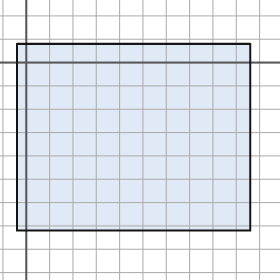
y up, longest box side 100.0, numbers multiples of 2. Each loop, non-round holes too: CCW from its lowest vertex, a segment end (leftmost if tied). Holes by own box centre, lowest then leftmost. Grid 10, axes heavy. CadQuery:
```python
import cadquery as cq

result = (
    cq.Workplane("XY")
    .moveTo(-4.0, -72.0)
    .lineTo(96.0, -72.0)
    .lineTo(96.0, 8.0)
    .lineTo(-4.0, 8.0)
    .close()
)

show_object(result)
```